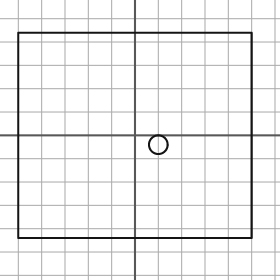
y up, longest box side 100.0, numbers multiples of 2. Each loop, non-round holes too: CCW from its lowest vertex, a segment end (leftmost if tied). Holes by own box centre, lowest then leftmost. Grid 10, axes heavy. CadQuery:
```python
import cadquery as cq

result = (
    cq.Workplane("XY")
    .moveTo(-50.0, -44.0)
    .lineTo(50.0, -44.0)
    .lineTo(50.0, 44.0)
    .lineTo(-50.0, 44.0)
    .close()
    .moveTo(10.0, -4.0)
    .circle(4.0)
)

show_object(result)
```